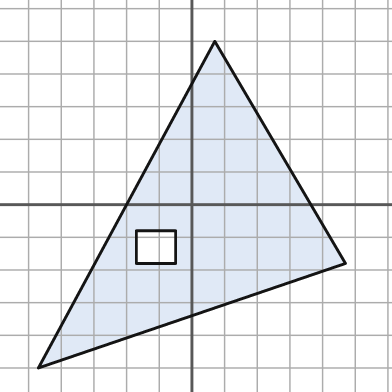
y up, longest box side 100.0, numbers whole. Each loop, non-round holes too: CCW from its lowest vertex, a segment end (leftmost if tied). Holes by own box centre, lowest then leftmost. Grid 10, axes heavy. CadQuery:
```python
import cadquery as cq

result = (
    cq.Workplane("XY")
    .moveTo(-47.0, -50.0)
    .lineTo(47.0, -18.0)
    .lineTo(7.0, 50.0)
    .close()
    .moveTo(-17.0, -18.0)
    .lineTo(-5.0, -18.0)
    .lineTo(-5.0, -8.0)
    .lineTo(-17.0, -8.0)
    .close()
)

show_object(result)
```